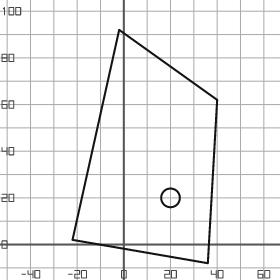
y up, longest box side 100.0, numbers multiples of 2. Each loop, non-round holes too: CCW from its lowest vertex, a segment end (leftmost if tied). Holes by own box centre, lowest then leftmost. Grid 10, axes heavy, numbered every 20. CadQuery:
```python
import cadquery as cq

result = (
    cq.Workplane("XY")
    .moveTo(36.0, -8.0)
    .lineTo(40.0, 62.0)
    .lineTo(-2.0, 92.0)
    .lineTo(-22.0, 2.0)
    .close()
    .moveTo(20.0, 20.0)
    .circle(4.0)
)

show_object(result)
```